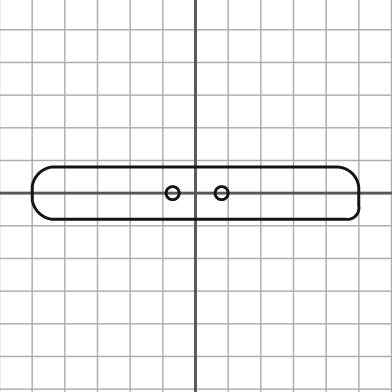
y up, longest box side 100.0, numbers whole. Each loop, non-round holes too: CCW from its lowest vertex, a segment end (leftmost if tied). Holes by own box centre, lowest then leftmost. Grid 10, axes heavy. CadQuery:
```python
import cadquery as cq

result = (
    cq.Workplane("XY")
    .moveTo(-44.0, -8.0)
    .lineTo(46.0, -8.0)
    .threePointArc((49.0, -7.0), (50.0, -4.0))
    .lineTo(50.0, 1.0)
    .threePointArc((48.0, 6.0), (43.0, 8.0))
    .lineTo(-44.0, 8.0)
    .threePointArc((-48.0, 6.0), (-50.0, 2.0))
    .lineTo(-50.0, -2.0)
    .threePointArc((-48.0, -6.0), (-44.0, -8.0))
    .close()
    .moveTo(-7.0, 0.0)
    .circle(2.0)
    .moveTo(8.0, 0.0)
    .circle(2.0)
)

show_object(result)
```